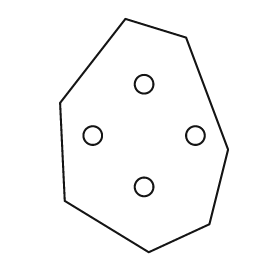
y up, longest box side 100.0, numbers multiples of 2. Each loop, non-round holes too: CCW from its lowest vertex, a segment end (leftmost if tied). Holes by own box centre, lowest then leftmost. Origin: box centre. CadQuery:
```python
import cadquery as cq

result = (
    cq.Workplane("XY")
    .moveTo(2.0, -50.0)
    .lineTo(28.0, -38.0)
    .lineTo(36.0, -6.0)
    .lineTo(18.0, 42.0)
    .lineTo(-8.0, 50.0)
    .lineTo(-36.0, 14.0)
    .lineTo(-34.0, -28.0)
    .close()
    .moveTo(0.0, -22.0)
    .circle(4.0)
    .moveTo(-22.0, 0.0)
    .circle(4.0)
    .moveTo(22.0, 0.0)
    .circle(4.0)
    .moveTo(0.0, 22.0)
    .circle(4.0)
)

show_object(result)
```